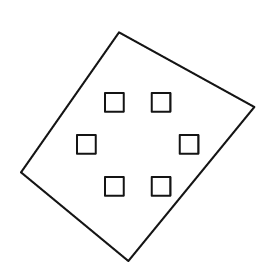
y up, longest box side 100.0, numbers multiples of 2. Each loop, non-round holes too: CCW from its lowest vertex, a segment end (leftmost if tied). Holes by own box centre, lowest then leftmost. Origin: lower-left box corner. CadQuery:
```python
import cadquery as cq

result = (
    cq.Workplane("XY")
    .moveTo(46.0, 0.0)
    .lineTo(100.0, 66.0)
    .lineTo(42.0, 98.0)
    .lineTo(0.0, 38.0)
    .close()
    .moveTo(36.0, 28.0)
    .lineTo(44.0, 28.0)
    .lineTo(44.0, 36.0)
    .lineTo(36.0, 36.0)
    .close()
    .moveTo(56.0, 28.0)
    .lineTo(64.0, 28.0)
    .lineTo(64.0, 36.0)
    .lineTo(56.0, 36.0)
    .close()
    .moveTo(24.0, 46.0)
    .lineTo(32.0, 46.0)
    .lineTo(32.0, 54.0)
    .lineTo(24.0, 54.0)
    .close()
    .moveTo(68.0, 46.0)
    .lineTo(76.0, 46.0)
    .lineTo(76.0, 54.0)
    .lineTo(68.0, 54.0)
    .close()
    .moveTo(36.0, 64.0)
    .lineTo(44.0, 64.0)
    .lineTo(44.0, 72.0)
    .lineTo(36.0, 72.0)
    .close()
    .moveTo(56.0, 64.0)
    .lineTo(64.0, 64.0)
    .lineTo(64.0, 72.0)
    .lineTo(56.0, 72.0)
    .close()
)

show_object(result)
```